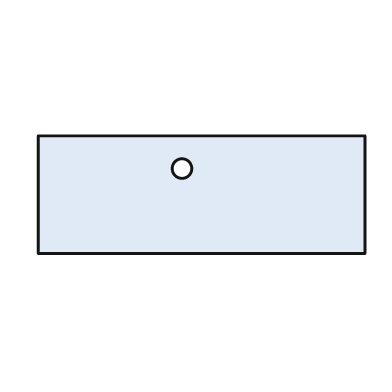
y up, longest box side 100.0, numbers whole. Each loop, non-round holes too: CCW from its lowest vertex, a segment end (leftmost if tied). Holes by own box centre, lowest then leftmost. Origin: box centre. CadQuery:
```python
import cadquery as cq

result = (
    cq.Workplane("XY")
    .moveTo(-50.0, -18.0)
    .lineTo(50.0, -18.0)
    .lineTo(50.0, 18.0)
    .lineTo(-50.0, 18.0)
    .close()
    .moveTo(-6.0, 8.0)
    .circle(3.0)
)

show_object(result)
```